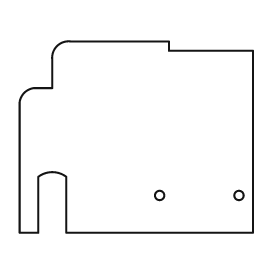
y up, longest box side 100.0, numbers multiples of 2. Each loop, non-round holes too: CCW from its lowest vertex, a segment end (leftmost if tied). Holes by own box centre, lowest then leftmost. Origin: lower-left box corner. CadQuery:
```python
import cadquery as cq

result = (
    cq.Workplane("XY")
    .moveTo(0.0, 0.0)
    .lineTo(8.0, 0.0)
    .lineTo(8.0, 24.0)
    .threePointArc((14.0, 26.0), (20.0, 24.0))
    .lineTo(20.0, 0.0)
    .lineTo(100.0, 0.0)
    .lineTo(100.0, 78.0)
    .lineTo(64.0, 78.0)
    .lineTo(64.0, 82.0)
    .lineTo(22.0, 82.0)
    .threePointArc((16.0, 80.0), (14.0, 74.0))
    .lineTo(14.0, 62.0)
    .lineTo(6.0, 62.0)
    .threePointArc((2.0, 60.0), (0.0, 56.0))
    .close()
    .moveTo(60.0, 16.0)
    .circle(2.0)
    .moveTo(94.0, 16.0)
    .circle(2.0)
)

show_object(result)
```